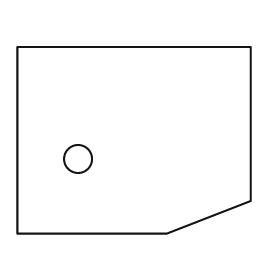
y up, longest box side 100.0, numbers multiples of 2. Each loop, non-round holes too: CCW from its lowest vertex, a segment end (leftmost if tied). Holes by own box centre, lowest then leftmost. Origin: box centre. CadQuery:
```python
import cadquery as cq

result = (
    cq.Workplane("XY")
    .moveTo(-50.0, -40.0)
    .lineTo(14.0, -40.0)
    .lineTo(50.0, -26.0)
    .lineTo(50.0, 40.0)
    .lineTo(-50.0, 40.0)
    .close()
    .moveTo(-24.0, -8.0)
    .circle(6.0)
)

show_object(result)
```